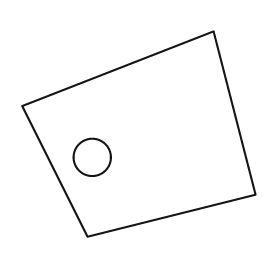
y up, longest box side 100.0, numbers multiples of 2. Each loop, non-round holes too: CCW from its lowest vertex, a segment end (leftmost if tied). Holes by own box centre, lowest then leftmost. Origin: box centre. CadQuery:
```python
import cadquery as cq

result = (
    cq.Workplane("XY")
    .moveTo(-22.0, -44.0)
    .lineTo(50.0, -26.0)
    .lineTo(32.0, 44.0)
    .lineTo(-50.0, 12.0)
    .close()
    .moveTo(-20.0, -10.0)
    .circle(8.0)
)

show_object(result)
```